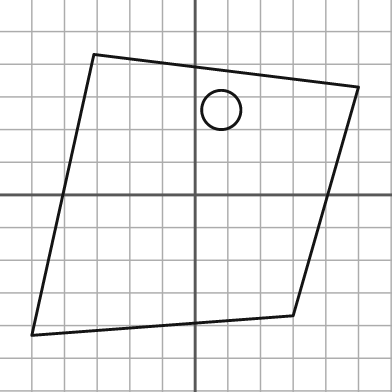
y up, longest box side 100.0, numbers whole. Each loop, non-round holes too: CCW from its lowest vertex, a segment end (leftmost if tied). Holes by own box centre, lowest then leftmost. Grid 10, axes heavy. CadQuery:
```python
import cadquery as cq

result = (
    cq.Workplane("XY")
    .moveTo(-50.0, -43.0)
    .lineTo(30.0, -37.0)
    .lineTo(50.0, 33.0)
    .lineTo(-31.0, 43.0)
    .close()
    .moveTo(8.0, 26.0)
    .circle(6.0)
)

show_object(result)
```